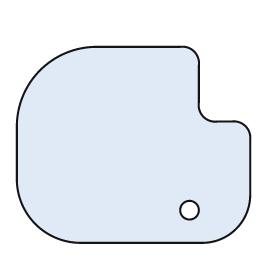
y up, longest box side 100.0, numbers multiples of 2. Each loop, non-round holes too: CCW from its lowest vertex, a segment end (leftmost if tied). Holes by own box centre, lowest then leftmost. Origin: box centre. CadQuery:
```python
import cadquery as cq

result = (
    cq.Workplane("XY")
    .moveTo(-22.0, -42.0)
    .lineTo(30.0, -42.0)
    .threePointArc((44.0, -36.0), (50.0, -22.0))
    .lineTo(50.0, 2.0)
    .threePointArc((48.0, 8.0), (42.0, 10.0))
    .lineTo(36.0, 10.0)
    .threePointArc((30.0, 12.0), (28.0, 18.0))
    .lineTo(28.0, 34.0)
    .threePointArc((26.0, 40.0), (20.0, 42.0))
    .lineTo(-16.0, 42.0)
    .threePointArc((-40.0, 32.0), (-50.0, 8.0))
    .lineTo(-50.0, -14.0)
    .threePointArc((-42.0, -34.0), (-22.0, -42.0))
    .close()
    .moveTo(24.0, -28.0)
    .circle(4.0)
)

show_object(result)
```